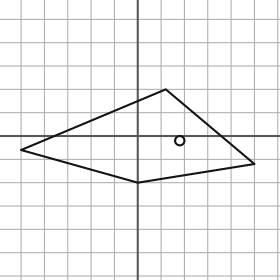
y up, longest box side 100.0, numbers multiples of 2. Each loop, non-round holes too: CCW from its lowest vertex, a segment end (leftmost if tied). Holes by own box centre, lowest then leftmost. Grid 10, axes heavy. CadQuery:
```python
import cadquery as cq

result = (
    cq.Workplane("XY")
    .moveTo(0.0, -20.0)
    .lineTo(50.0, -12.0)
    .lineTo(12.0, 20.0)
    .lineTo(-50.0, -6.0)
    .close()
    .moveTo(18.0, -2.0)
    .circle(2.0)
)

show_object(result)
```